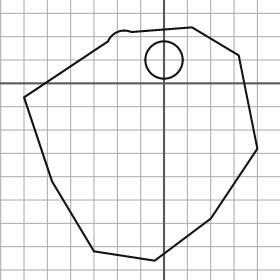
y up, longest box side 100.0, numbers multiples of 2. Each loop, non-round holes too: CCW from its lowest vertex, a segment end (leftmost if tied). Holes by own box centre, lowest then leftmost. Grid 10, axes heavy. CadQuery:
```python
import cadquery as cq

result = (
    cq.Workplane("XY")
    .moveTo(-4.0, -76.0)
    .lineTo(20.0, -58.0)
    .lineTo(40.0, -28.0)
    .lineTo(32.0, 12.0)
    .lineTo(12.0, 24.0)
    .lineTo(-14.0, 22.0)
    .threePointArc((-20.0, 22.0), (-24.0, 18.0))
    .lineTo(-60.0, -6.0)
    .lineTo(-48.0, -42.0)
    .lineTo(-30.0, -72.0)
    .close()
    .moveTo(0.0, 10.0)
    .circle(8.0)
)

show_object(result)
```